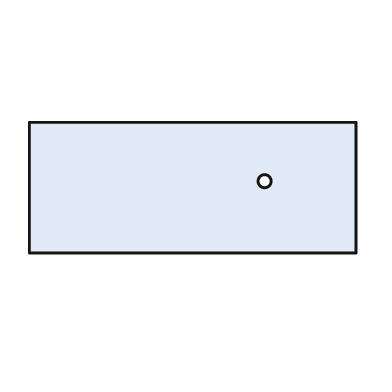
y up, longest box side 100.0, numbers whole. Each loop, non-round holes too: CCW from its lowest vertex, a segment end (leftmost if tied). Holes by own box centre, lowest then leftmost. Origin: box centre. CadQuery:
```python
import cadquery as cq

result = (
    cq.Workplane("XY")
    .moveTo(-50.0, -20.0)
    .lineTo(50.0, -20.0)
    .lineTo(50.0, 20.0)
    .lineTo(-50.0, 20.0)
    .close()
    .moveTo(22.0, 2.0)
    .circle(2.0)
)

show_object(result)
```